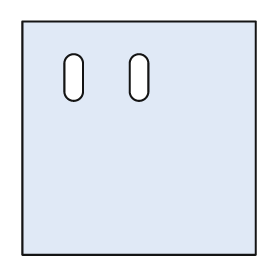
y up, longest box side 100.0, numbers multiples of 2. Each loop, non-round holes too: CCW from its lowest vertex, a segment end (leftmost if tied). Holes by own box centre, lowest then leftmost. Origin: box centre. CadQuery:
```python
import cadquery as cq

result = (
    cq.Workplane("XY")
    .moveTo(-50.0, -50.0)
    .lineTo(50.0, -50.0)
    .lineTo(50.0, 50.0)
    .lineTo(-50.0, 50.0)
    .close()
    .moveTo(-32.0, 20.0)
    .threePointArc((-28.0, 16.0), (-24.0, 20.0))
    .lineTo(-24.0, 32.0)
    .threePointArc((-28.0, 36.0), (-32.0, 32.0))
    .close()
    .moveTo(-4.0, 20.0)
    .threePointArc((0.0, 16.0), (4.0, 20.0))
    .lineTo(4.0, 32.0)
    .threePointArc((0.0, 36.0), (-4.0, 32.0))
    .close()
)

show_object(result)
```